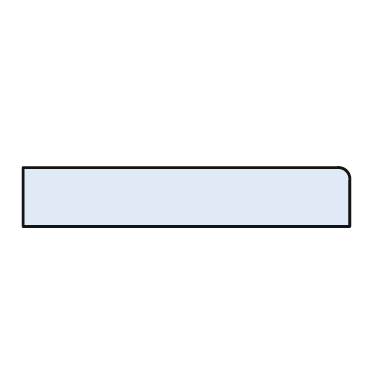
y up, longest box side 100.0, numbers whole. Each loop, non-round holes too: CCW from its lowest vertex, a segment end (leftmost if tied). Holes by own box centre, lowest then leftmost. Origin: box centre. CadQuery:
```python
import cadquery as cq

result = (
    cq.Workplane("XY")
    .moveTo(-50.0, -9.0)
    .lineTo(50.0, -9.0)
    .lineTo(50.0, 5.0)
    .threePointArc((49.0, 8.0), (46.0, 9.0))
    .lineTo(-50.0, 9.0)
    .close()
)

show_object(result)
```